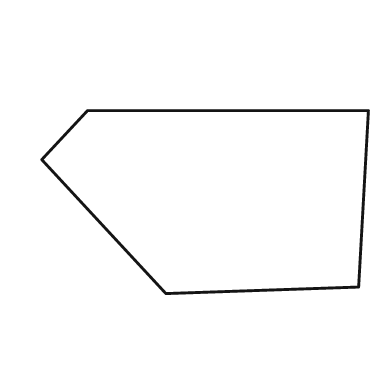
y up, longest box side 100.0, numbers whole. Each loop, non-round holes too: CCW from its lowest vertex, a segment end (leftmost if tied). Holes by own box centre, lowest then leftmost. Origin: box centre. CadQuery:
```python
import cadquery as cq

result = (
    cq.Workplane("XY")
    .moveTo(-12.0, -28.0)
    .lineTo(47.0, -26.0)
    .lineTo(50.0, 28.0)
    .lineTo(-36.0, 28.0)
    .lineTo(-50.0, 13.0)
    .close()
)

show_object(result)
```